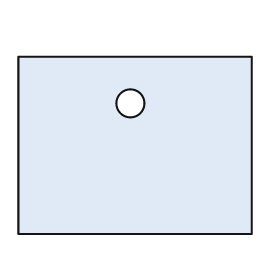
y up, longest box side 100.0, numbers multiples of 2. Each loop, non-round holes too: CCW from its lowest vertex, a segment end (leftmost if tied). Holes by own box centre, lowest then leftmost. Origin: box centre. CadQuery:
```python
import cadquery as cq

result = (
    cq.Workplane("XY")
    .moveTo(-50.0, -38.0)
    .lineTo(50.0, -38.0)
    .lineTo(50.0, 38.0)
    .lineTo(-50.0, 38.0)
    .close()
    .moveTo(-2.0, 18.0)
    .circle(6.0)
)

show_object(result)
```